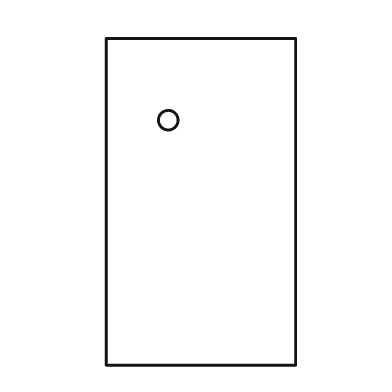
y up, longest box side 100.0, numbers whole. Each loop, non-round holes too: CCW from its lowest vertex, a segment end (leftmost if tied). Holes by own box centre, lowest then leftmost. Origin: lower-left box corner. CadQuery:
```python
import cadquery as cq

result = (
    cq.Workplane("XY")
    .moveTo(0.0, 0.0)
    .lineTo(58.0, 0.0)
    .lineTo(58.0, 100.0)
    .lineTo(0.0, 100.0)
    .close()
    .moveTo(19.0, 75.0)
    .circle(3.0)
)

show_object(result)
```